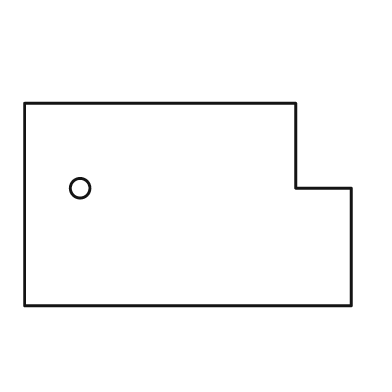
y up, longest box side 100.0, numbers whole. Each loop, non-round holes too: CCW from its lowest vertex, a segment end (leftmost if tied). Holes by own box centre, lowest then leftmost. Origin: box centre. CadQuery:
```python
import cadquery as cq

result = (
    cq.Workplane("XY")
    .moveTo(-50.0, -31.0)
    .lineTo(50.0, -31.0)
    .lineTo(50.0, 5.0)
    .lineTo(33.0, 5.0)
    .lineTo(33.0, 31.0)
    .lineTo(-50.0, 31.0)
    .close()
    .moveTo(-33.0, 5.0)
    .circle(3.0)
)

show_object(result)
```